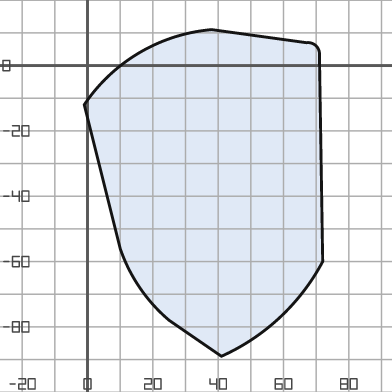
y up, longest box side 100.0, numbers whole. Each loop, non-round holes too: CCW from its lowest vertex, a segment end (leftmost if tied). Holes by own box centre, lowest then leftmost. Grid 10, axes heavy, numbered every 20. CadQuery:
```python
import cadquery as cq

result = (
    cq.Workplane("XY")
    .moveTo(41.0, -89.0)
    .threePointArc((59.0, -77.0), (72.0, -60.0))
    .lineTo(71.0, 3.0)
    .threePointArc((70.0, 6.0), (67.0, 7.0))
    .lineTo(38.0, 11.0)
    .threePointArc((16.0, 4.0), (-1.0, -12.0))
    .lineTo(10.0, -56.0)
    .threePointArc((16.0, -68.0), (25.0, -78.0))
    .close()
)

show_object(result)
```